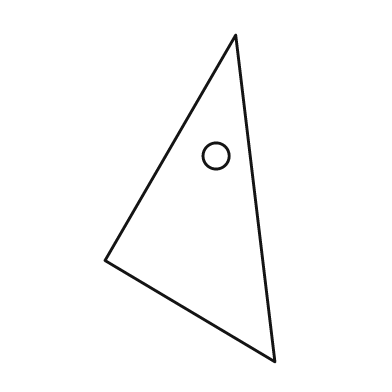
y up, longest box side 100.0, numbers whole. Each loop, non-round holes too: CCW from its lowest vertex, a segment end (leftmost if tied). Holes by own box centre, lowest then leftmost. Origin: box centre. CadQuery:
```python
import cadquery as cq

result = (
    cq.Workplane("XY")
    .moveTo(26.0, -50.0)
    .lineTo(14.0, 50.0)
    .lineTo(-26.0, -19.0)
    .close()
    .moveTo(8.0, 13.0)
    .circle(4.0)
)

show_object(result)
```